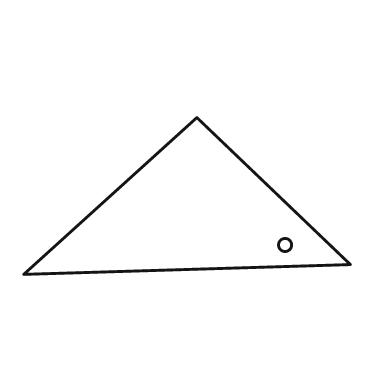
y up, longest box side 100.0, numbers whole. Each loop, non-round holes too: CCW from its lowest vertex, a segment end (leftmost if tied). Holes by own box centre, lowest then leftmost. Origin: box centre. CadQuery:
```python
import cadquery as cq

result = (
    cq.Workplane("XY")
    .moveTo(-50.0, -24.0)
    .lineTo(50.0, -21.0)
    .lineTo(3.0, 24.0)
    .close()
    .moveTo(30.0, -15.0)
    .circle(2.0)
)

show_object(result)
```